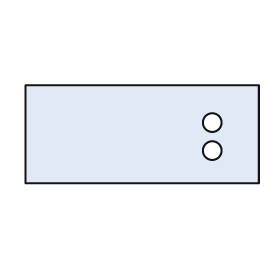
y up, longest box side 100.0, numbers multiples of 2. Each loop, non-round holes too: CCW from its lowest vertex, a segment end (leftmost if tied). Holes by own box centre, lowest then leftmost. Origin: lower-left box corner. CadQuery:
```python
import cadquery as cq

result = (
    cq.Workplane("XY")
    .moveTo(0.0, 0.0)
    .lineTo(100.0, 0.0)
    .lineTo(100.0, 42.0)
    .lineTo(0.0, 42.0)
    .close()
    .moveTo(80.0, 14.0)
    .circle(4.0)
    .moveTo(80.0, 26.0)
    .circle(4.0)
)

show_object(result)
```